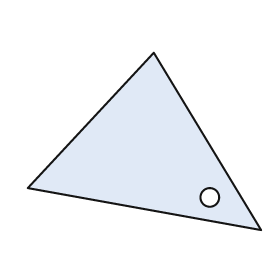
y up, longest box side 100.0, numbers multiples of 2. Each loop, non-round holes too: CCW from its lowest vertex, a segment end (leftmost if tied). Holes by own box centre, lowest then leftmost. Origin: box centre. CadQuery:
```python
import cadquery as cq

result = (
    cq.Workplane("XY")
    .moveTo(50.0, -38.0)
    .lineTo(4.0, 38.0)
    .lineTo(-50.0, -20.0)
    .close()
    .moveTo(28.0, -24.0)
    .circle(4.0)
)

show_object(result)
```